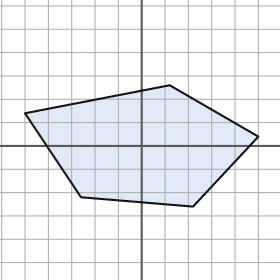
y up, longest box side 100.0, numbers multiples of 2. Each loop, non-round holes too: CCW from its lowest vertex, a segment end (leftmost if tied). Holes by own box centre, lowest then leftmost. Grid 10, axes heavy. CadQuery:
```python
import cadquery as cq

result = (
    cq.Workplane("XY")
    .moveTo(22.0, -26.0)
    .lineTo(50.0, 4.0)
    .lineTo(12.0, 26.0)
    .lineTo(-50.0, 14.0)
    .lineTo(-26.0, -22.0)
    .close()
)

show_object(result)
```